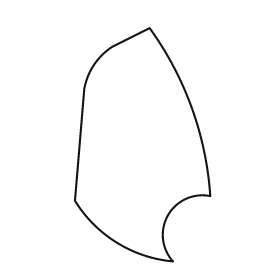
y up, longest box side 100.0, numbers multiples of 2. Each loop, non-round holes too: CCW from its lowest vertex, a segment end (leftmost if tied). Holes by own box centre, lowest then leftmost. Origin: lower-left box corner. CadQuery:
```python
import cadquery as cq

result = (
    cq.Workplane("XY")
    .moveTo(42.0, 0.0)
    .threePointArc((40.0, 20.0), (58.0, 28.0))
    .threePointArc((50.0, 66.0), (32.0, 100.0))
    .lineTo(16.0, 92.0)
    .threePointArc((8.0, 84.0), (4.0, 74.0))
    .lineTo(0.0, 26.0)
    .threePointArc((18.0, 8.0), (42.0, 0.0))
    .close()
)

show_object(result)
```